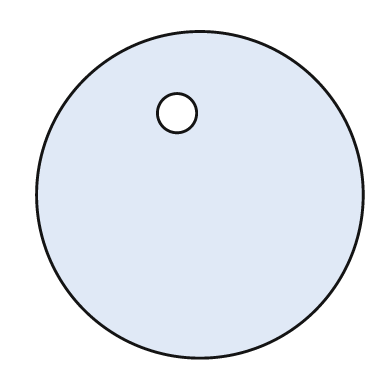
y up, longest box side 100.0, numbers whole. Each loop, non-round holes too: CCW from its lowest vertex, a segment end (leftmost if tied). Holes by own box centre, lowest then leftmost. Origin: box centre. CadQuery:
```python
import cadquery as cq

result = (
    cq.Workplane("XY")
    .moveTo(0.0, 0.0)
    .circle(50.0)
    .moveTo(-7.0, 25.0)
    .circle(6.0)
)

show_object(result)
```